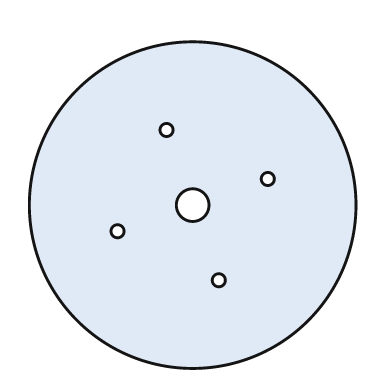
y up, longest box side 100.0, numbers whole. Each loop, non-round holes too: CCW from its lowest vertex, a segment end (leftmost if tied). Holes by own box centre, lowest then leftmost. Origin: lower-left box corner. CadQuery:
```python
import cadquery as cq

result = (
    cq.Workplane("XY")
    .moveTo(50.0, 50.0)
    .circle(50.0)
    .moveTo(58.0, 27.0)
    .circle(2.0)
    .moveTo(27.0, 42.0)
    .circle(2.0)
    .moveTo(50.0, 50.0)
    .circle(5.0)
    .moveTo(73.0, 58.0)
    .circle(2.0)
    .moveTo(42.0, 73.0)
    .circle(2.0)
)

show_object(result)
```